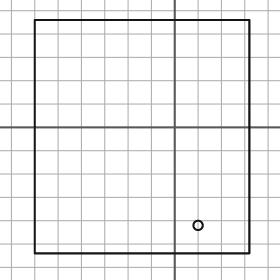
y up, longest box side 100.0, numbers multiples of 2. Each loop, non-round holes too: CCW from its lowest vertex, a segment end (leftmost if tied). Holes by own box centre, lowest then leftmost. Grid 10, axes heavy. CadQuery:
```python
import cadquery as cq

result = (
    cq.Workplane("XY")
    .moveTo(-60.0, -54.0)
    .lineTo(32.0, -54.0)
    .lineTo(32.0, 46.0)
    .lineTo(-60.0, 46.0)
    .close()
    .moveTo(10.0, -42.0)
    .circle(2.0)
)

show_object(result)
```